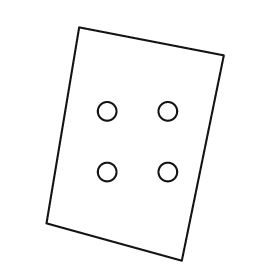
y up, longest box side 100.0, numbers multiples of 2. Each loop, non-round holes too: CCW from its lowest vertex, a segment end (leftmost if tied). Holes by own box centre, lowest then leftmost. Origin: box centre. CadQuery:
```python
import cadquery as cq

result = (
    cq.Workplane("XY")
    .moveTo(20.0, -50.0)
    .lineTo(38.0, 38.0)
    .lineTo(-24.0, 50.0)
    .lineTo(-38.0, -34.0)
    .close()
    .moveTo(-12.0, -12.0)
    .circle(4.0)
    .moveTo(14.0, -12.0)
    .circle(4.0)
    .moveTo(-12.0, 14.0)
    .circle(4.0)
    .moveTo(14.0, 14.0)
    .circle(4.0)
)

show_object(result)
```